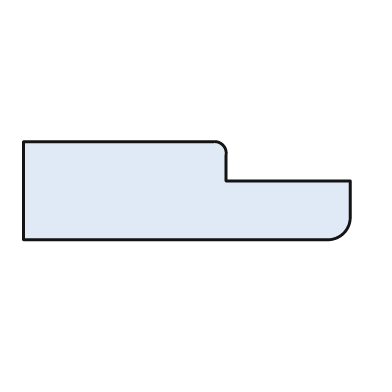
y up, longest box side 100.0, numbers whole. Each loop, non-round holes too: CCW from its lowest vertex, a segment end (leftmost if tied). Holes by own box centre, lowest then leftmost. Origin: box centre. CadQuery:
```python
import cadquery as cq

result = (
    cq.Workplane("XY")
    .moveTo(-50.0, -15.0)
    .lineTo(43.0, -15.0)
    .threePointArc((48.0, -13.0), (50.0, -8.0))
    .lineTo(50.0, 3.0)
    .lineTo(12.0, 3.0)
    .lineTo(12.0, 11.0)
    .threePointArc((11.0, 14.0), (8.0, 15.0))
    .lineTo(-50.0, 15.0)
    .close()
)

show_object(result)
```